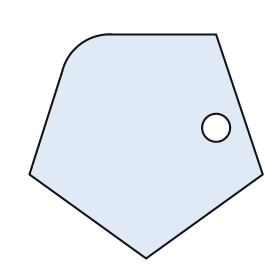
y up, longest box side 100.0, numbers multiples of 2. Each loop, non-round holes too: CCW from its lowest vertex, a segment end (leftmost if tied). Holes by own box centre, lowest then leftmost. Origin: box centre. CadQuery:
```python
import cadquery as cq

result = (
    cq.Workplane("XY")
    .moveTo(0.0, -48.0)
    .lineTo(50.0, -12.0)
    .lineTo(30.0, 48.0)
    .lineTo(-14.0, 48.0)
    .threePointArc((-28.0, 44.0), (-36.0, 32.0))
    .lineTo(-50.0, -12.0)
    .close()
    .moveTo(30.0, 8.0)
    .circle(6.0)
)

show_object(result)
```